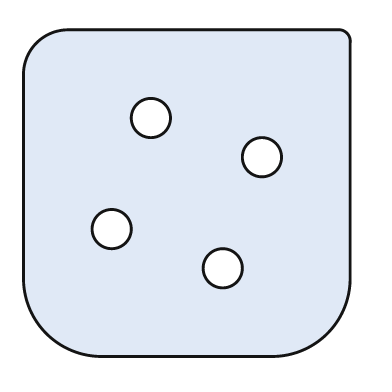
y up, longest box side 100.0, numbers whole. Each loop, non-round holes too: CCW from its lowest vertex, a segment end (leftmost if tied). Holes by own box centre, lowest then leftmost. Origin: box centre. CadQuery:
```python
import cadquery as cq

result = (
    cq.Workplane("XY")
    .moveTo(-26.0, -50.0)
    .lineTo(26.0, -50.0)
    .threePointArc((43.0, -43.0), (50.0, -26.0))
    .lineTo(50.0, 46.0)
    .threePointArc((49.0, 49.0), (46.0, 50.0))
    .lineTo(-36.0, 50.0)
    .threePointArc((-46.0, 46.0), (-50.0, 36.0))
    .lineTo(-50.0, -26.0)
    .threePointArc((-43.0, -43.0), (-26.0, -50.0))
    .close()
    .moveTo(11.0, -23.0)
    .circle(6.0)
    .moveTo(-23.0, -11.0)
    .circle(6.0)
    .moveTo(23.0, 11.0)
    .circle(6.0)
    .moveTo(-11.0, 23.0)
    .circle(6.0)
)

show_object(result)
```